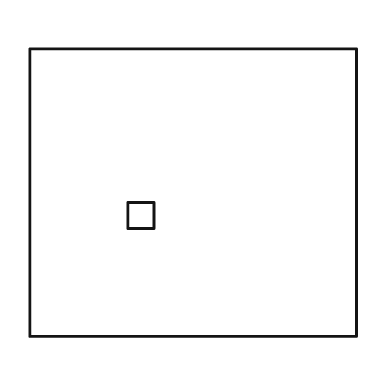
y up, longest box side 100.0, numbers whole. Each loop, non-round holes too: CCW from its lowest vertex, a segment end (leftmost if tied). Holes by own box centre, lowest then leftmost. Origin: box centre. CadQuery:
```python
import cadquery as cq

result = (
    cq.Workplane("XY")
    .moveTo(-50.0, -44.0)
    .lineTo(50.0, -44.0)
    .lineTo(50.0, 44.0)
    .lineTo(-50.0, 44.0)
    .close()
    .moveTo(-20.0, -11.0)
    .lineTo(-12.0, -11.0)
    .lineTo(-12.0, -3.0)
    .lineTo(-20.0, -3.0)
    .close()
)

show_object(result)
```